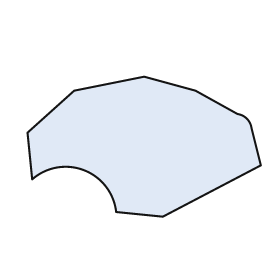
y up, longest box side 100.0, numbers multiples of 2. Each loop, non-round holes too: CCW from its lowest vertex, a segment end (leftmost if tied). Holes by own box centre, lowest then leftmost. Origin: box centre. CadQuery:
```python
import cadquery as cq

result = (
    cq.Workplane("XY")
    .moveTo(8.0, -30.0)
    .lineTo(50.0, -8.0)
    .lineTo(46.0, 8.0)
    .threePointArc((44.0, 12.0), (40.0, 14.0))
    .lineTo(22.0, 24.0)
    .lineTo(0.0, 30.0)
    .lineTo(-30.0, 24.0)
    .lineTo(-50.0, 6.0)
    .lineTo(-48.0, -14.0)
    .threePointArc((-26.0, -10.0), (-12.0, -28.0))
    .close()
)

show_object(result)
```